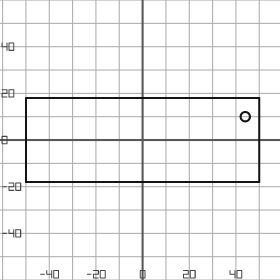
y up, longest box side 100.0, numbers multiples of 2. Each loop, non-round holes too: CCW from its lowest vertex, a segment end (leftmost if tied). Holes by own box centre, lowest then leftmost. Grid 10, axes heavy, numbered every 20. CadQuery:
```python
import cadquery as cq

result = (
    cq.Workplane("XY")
    .moveTo(-50.0, -18.0)
    .lineTo(50.0, -18.0)
    .lineTo(50.0, 18.0)
    .lineTo(-50.0, 18.0)
    .close()
    .moveTo(44.0, 10.0)
    .circle(2.0)
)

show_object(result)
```